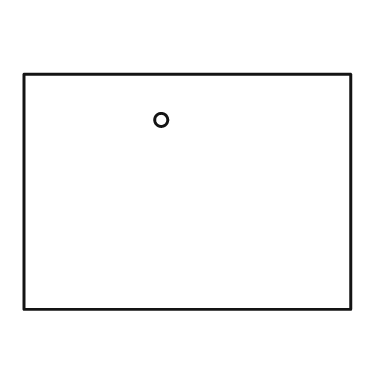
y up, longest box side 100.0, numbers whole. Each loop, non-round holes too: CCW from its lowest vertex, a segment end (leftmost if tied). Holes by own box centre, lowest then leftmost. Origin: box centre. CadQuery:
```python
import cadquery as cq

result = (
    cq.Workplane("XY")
    .moveTo(-50.0, -36.0)
    .lineTo(50.0, -36.0)
    .lineTo(50.0, 36.0)
    .lineTo(-50.0, 36.0)
    .close()
    .moveTo(-8.0, 22.0)
    .circle(2.0)
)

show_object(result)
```